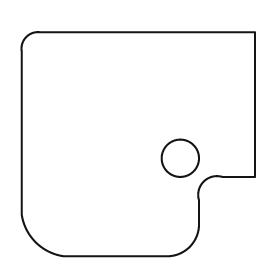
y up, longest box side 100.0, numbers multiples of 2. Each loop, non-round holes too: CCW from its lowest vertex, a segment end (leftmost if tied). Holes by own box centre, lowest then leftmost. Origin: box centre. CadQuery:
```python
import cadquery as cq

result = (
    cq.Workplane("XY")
    .moveTo(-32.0, -48.0)
    .lineTo(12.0, -48.0)
    .threePointArc((22.0, -44.0), (26.0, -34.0))
    .lineTo(26.0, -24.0)
    .threePointArc((28.0, -16.0), (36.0, -14.0))
    .lineTo(50.0, -14.0)
    .lineTo(50.0, 48.0)
    .lineTo(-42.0, 48.0)
    .threePointArc((-48.0, 46.0), (-50.0, 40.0))
    .lineTo(-50.0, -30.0)
    .threePointArc((-44.0, -42.0), (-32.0, -48.0))
    .close()
    .moveTo(18.0, -6.0)
    .circle(8.0)
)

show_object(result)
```